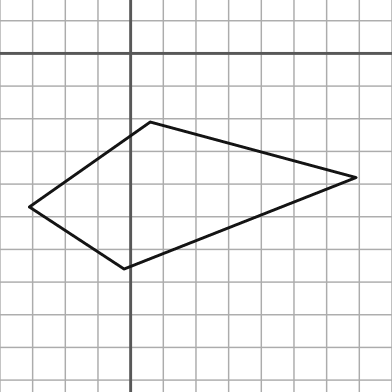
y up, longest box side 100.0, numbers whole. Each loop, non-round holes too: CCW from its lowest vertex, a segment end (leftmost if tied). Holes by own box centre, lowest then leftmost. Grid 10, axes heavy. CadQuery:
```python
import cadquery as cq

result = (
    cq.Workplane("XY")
    .moveTo(-2.0, -66.0)
    .lineTo(69.0, -38.0)
    .lineTo(6.0, -21.0)
    .lineTo(-31.0, -47.0)
    .close()
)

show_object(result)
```